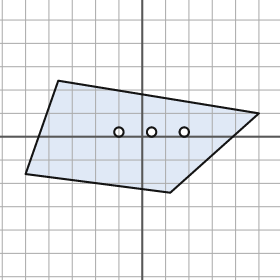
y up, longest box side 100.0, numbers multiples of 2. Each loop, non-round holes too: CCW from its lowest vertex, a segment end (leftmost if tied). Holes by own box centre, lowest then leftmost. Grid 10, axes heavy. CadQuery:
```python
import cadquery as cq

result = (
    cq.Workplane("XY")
    .moveTo(12.0, -24.0)
    .lineTo(50.0, 10.0)
    .lineTo(-36.0, 24.0)
    .lineTo(-50.0, -16.0)
    .close()
    .moveTo(-10.0, 2.0)
    .circle(2.0)
    .moveTo(4.0, 2.0)
    .circle(2.0)
    .moveTo(18.0, 2.0)
    .circle(2.0)
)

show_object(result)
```